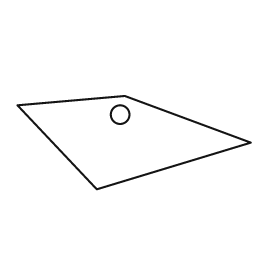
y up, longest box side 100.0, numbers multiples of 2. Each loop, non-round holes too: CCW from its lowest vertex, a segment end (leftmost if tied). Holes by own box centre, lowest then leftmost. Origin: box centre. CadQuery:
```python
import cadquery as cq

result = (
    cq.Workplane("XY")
    .moveTo(-16.0, -20.0)
    .lineTo(50.0, 0.0)
    .lineTo(-4.0, 20.0)
    .lineTo(-50.0, 16.0)
    .close()
    .moveTo(-6.0, 12.0)
    .circle(4.0)
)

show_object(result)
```